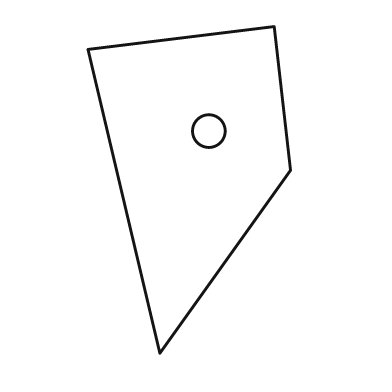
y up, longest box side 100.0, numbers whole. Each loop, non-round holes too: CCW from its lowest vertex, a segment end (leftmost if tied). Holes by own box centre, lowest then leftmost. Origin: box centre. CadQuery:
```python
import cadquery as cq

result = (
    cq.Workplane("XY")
    .moveTo(-9.0, -50.0)
    .lineTo(31.0, 6.0)
    .lineTo(26.0, 50.0)
    .lineTo(-31.0, 43.0)
    .close()
    .moveTo(6.0, 18.0)
    .circle(5.0)
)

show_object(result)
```